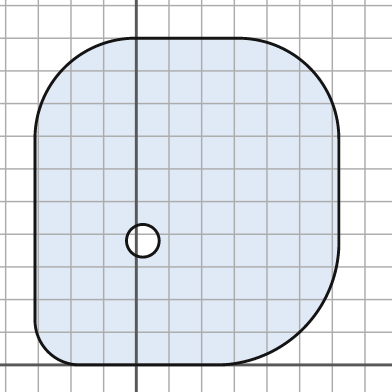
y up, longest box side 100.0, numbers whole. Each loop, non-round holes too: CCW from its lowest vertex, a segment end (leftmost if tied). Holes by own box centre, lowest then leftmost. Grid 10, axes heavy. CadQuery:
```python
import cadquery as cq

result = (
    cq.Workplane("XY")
    .moveTo(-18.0, 0.0)
    .lineTo(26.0, 0.0)
    .threePointArc((51.0, 11.0), (62.0, 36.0))
    .lineTo(62.0, 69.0)
    .threePointArc((53.0, 91.0), (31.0, 100.0))
    .lineTo(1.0, 100.0)
    .threePointArc((-22.0, 91.0), (-31.0, 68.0))
    .lineTo(-31.0, 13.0)
    .threePointArc((-27.0, 4.0), (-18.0, 0.0))
    .close()
    .moveTo(2.0, 38.0)
    .circle(5.0)
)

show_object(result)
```